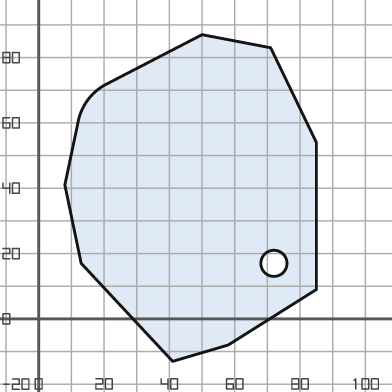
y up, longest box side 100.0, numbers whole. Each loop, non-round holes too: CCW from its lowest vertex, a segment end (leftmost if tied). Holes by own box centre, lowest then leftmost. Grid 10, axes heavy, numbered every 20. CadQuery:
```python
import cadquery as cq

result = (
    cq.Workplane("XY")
    .moveTo(41.0, -13.0)
    .lineTo(58.0, -8.0)
    .lineTo(85.0, 9.0)
    .lineTo(85.0, 54.0)
    .lineTo(71.0, 83.0)
    .lineTo(50.0, 87.0)
    .lineTo(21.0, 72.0)
    .threePointArc((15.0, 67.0), (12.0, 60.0))
    .lineTo(8.0, 41.0)
    .lineTo(13.0, 17.0)
    .close()
    .moveTo(72.0, 17.0)
    .circle(4.0)
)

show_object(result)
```